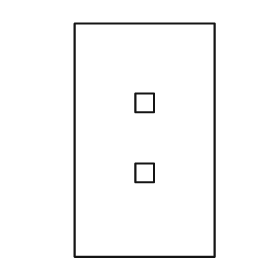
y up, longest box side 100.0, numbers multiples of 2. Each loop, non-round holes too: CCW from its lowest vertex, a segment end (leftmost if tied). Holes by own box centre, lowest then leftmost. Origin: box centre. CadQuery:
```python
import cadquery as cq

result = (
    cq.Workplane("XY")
    .moveTo(-30.0, -50.0)
    .lineTo(30.0, -50.0)
    .lineTo(30.0, 50.0)
    .lineTo(-30.0, 50.0)
    .close()
    .moveTo(-4.0, -18.0)
    .lineTo(4.0, -18.0)
    .lineTo(4.0, -10.0)
    .lineTo(-4.0, -10.0)
    .close()
    .moveTo(-4.0, 12.0)
    .lineTo(4.0, 12.0)
    .lineTo(4.0, 20.0)
    .lineTo(-4.0, 20.0)
    .close()
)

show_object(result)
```